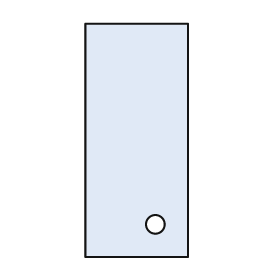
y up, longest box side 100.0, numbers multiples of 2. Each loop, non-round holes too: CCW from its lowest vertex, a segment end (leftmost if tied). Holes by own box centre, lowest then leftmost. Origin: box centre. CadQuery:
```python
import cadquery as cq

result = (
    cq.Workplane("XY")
    .moveTo(-22.0, -50.0)
    .lineTo(22.0, -50.0)
    .lineTo(22.0, 50.0)
    .lineTo(-22.0, 50.0)
    .close()
    .moveTo(8.0, -36.0)
    .circle(4.0)
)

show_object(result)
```